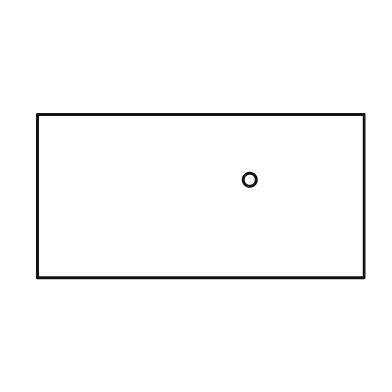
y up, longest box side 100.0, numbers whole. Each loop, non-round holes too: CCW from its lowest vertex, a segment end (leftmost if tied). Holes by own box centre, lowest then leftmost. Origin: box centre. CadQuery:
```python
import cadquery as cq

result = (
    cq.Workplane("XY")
    .moveTo(-50.0, -25.0)
    .lineTo(50.0, -25.0)
    .lineTo(50.0, 25.0)
    .lineTo(-50.0, 25.0)
    .close()
    .moveTo(15.0, 5.0)
    .circle(2.0)
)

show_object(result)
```